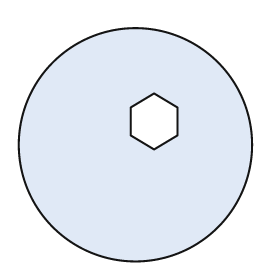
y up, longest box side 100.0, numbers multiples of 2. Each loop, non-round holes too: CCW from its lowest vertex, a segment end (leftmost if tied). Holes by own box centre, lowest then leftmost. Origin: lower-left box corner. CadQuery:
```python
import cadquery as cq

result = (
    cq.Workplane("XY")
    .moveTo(50.0, 50.0)
    .circle(50.0)
    .moveTo(58.0, 48.0)
    .lineTo(68.0, 54.0)
    .lineTo(68.0, 66.0)
    .lineTo(58.0, 72.0)
    .lineTo(48.0, 66.0)
    .lineTo(48.0, 54.0)
    .close()
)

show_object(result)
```